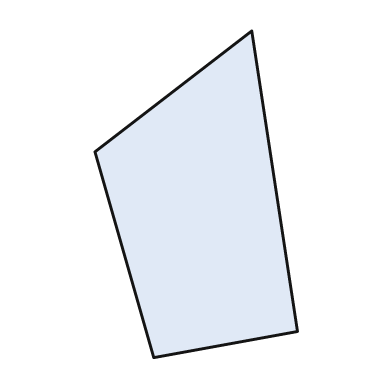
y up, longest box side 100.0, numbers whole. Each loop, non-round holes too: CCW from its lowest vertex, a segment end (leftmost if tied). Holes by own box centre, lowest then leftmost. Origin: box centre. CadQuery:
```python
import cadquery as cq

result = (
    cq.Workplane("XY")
    .moveTo(-13.0, -50.0)
    .lineTo(31.0, -42.0)
    .lineTo(17.0, 50.0)
    .lineTo(-31.0, 13.0)
    .close()
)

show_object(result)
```